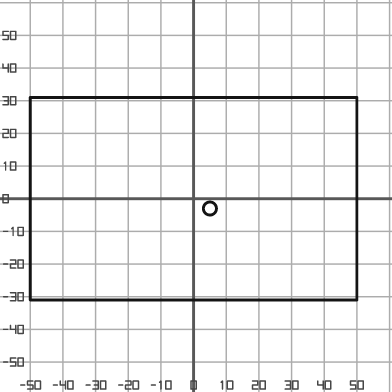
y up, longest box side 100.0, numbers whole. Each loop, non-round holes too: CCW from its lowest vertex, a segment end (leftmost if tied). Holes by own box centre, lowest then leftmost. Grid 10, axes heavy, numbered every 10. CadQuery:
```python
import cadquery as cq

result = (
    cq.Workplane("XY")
    .moveTo(-50.0, -31.0)
    .lineTo(50.0, -31.0)
    .lineTo(50.0, 31.0)
    .lineTo(-50.0, 31.0)
    .close()
    .moveTo(5.0, -3.0)
    .circle(2.0)
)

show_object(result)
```